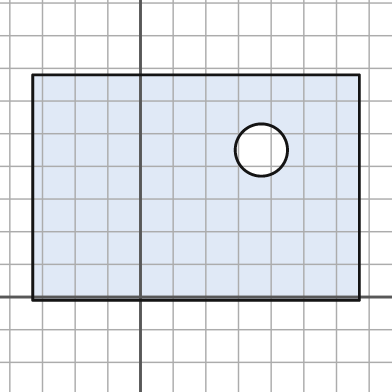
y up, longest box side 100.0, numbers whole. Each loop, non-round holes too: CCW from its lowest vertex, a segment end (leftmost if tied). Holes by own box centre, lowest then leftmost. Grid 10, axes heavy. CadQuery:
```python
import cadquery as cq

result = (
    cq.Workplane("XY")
    .moveTo(-33.0, -1.0)
    .lineTo(67.0, -1.0)
    .lineTo(67.0, 68.0)
    .lineTo(-33.0, 68.0)
    .close()
    .moveTo(37.0, 45.0)
    .circle(8.0)
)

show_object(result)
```